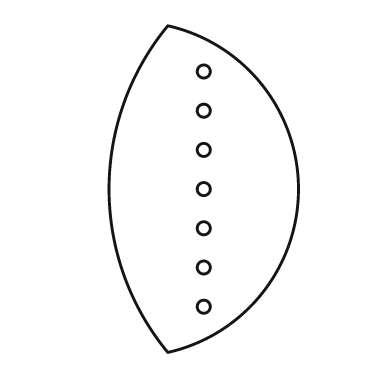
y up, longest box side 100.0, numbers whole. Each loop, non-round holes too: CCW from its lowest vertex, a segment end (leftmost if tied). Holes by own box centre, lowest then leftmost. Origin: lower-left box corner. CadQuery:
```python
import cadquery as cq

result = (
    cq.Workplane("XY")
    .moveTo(18.0, 0.0)
    .threePointArc((58.0, 50.0), (18.0, 100.0))
    .threePointArc((0.0, 50.0), (18.0, 0.0))
    .close()
    .moveTo(29.0, 14.0)
    .circle(2.0)
    .moveTo(29.0, 26.0)
    .circle(2.0)
    .moveTo(29.0, 38.0)
    .circle(2.0)
    .moveTo(29.0, 50.0)
    .circle(2.0)
    .moveTo(29.0, 62.0)
    .circle(2.0)
    .moveTo(29.0, 74.0)
    .circle(2.0)
    .moveTo(29.0, 86.0)
    .circle(2.0)
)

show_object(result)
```